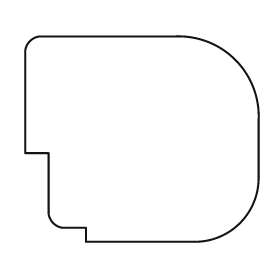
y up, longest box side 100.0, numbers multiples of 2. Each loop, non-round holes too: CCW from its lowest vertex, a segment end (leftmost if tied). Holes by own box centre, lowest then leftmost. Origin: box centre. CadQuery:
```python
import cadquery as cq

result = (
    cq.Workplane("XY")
    .moveTo(-24.0, -44.0)
    .lineTo(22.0, -44.0)
    .threePointArc((42.0, -36.0), (50.0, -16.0))
    .lineTo(50.0, 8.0)
    .threePointArc((40.0, 34.0), (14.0, 44.0))
    .lineTo(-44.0, 44.0)
    .threePointArc((-48.0, 42.0), (-50.0, 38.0))
    .lineTo(-50.0, -6.0)
    .lineTo(-40.0, -6.0)
    .lineTo(-40.0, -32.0)
    .threePointArc((-38.0, -36.0), (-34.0, -38.0))
    .lineTo(-24.0, -38.0)
    .close()
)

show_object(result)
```